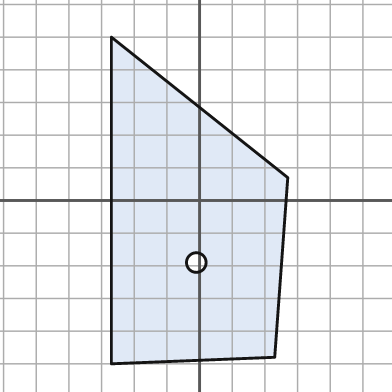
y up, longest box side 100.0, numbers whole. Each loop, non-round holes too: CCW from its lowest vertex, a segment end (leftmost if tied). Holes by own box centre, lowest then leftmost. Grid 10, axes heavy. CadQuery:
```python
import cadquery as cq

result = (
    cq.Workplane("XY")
    .moveTo(-27.0, -50.0)
    .lineTo(23.0, -48.0)
    .lineTo(27.0, 7.0)
    .lineTo(-27.0, 50.0)
    .close()
    .moveTo(-1.0, -19.0)
    .circle(3.0)
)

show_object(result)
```